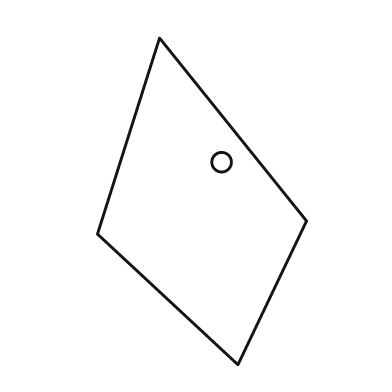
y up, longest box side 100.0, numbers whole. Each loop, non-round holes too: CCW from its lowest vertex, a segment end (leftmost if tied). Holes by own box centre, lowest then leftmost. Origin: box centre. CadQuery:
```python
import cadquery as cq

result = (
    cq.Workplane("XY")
    .moveTo(11.0, -50.0)
    .lineTo(32.0, -6.0)
    .lineTo(-13.0, 50.0)
    .lineTo(-32.0, -10.0)
    .close()
    .moveTo(6.0, 12.0)
    .circle(3.0)
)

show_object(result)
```